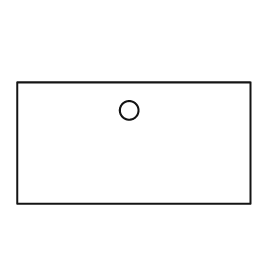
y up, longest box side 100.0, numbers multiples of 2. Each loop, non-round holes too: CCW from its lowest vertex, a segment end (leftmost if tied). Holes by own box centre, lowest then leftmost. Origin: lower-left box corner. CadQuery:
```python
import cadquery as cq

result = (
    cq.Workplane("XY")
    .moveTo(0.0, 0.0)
    .lineTo(100.0, 0.0)
    .lineTo(100.0, 52.0)
    .lineTo(0.0, 52.0)
    .close()
    .moveTo(48.0, 40.0)
    .circle(4.0)
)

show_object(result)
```